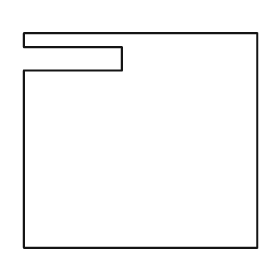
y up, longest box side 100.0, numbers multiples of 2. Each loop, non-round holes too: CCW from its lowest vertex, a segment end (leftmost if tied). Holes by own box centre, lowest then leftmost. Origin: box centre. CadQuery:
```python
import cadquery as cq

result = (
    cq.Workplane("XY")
    .moveTo(-50.0, -46.0)
    .lineTo(50.0, -46.0)
    .lineTo(50.0, 46.0)
    .lineTo(-50.0, 46.0)
    .lineTo(-50.0, 40.0)
    .lineTo(-8.0, 40.0)
    .lineTo(-8.0, 30.0)
    .lineTo(-50.0, 30.0)
    .close()
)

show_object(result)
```